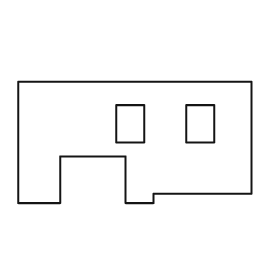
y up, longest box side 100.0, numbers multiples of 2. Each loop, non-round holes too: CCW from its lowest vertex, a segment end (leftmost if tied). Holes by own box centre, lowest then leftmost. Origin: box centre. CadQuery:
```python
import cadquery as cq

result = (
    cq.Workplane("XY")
    .moveTo(-50.0, -26.0)
    .lineTo(-32.0, -26.0)
    .lineTo(-32.0, -6.0)
    .lineTo(-4.0, -6.0)
    .lineTo(-4.0, -26.0)
    .lineTo(8.0, -26.0)
    .lineTo(8.0, -22.0)
    .lineTo(50.0, -22.0)
    .lineTo(50.0, 26.0)
    .lineTo(-50.0, 26.0)
    .close()
    .moveTo(-8.0, 0.0)
    .lineTo(4.0, 0.0)
    .lineTo(4.0, 16.0)
    .lineTo(-8.0, 16.0)
    .close()
    .moveTo(22.0, 0.0)
    .lineTo(34.0, 0.0)
    .lineTo(34.0, 16.0)
    .lineTo(22.0, 16.0)
    .close()
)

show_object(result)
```